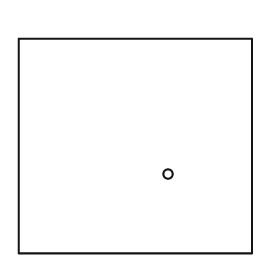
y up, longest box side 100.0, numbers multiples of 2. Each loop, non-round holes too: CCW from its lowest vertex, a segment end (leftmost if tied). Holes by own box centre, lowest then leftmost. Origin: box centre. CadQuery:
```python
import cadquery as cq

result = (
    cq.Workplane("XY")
    .moveTo(-50.0, -46.0)
    .lineTo(50.0, -46.0)
    .lineTo(50.0, 46.0)
    .lineTo(-50.0, 46.0)
    .close()
    .moveTo(14.0, -12.0)
    .circle(2.0)
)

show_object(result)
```